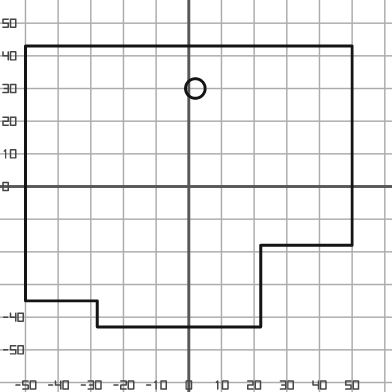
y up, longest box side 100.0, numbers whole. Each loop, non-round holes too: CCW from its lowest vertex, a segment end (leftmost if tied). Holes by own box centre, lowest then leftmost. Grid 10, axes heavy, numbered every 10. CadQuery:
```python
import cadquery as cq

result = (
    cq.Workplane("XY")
    .moveTo(-28.0, -43.0)
    .lineTo(22.0, -43.0)
    .lineTo(22.0, -18.0)
    .lineTo(50.0, -18.0)
    .lineTo(50.0, 43.0)
    .lineTo(-50.0, 43.0)
    .lineTo(-50.0, -35.0)
    .lineTo(-28.0, -35.0)
    .close()
    .moveTo(2.0, 30.0)
    .circle(3.0)
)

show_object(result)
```